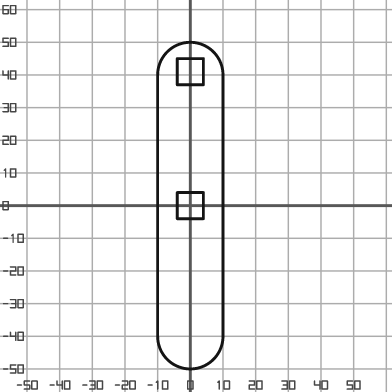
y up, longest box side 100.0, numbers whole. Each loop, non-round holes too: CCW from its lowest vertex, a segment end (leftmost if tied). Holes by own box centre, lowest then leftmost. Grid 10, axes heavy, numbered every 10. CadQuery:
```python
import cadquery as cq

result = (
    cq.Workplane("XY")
    .moveTo(-10.0, -40.0)
    .threePointArc((0.0, -50.0), (10.0, -40.0))
    .lineTo(10.0, 40.0)
    .threePointArc((0.0, 50.0), (-10.0, 40.0))
    .close()
    .moveTo(-4.0, -4.0)
    .lineTo(4.0, -4.0)
    .lineTo(4.0, 4.0)
    .lineTo(-4.0, 4.0)
    .close()
    .moveTo(-4.0, 37.0)
    .lineTo(4.0, 37.0)
    .lineTo(4.0, 45.0)
    .lineTo(-4.0, 45.0)
    .close()
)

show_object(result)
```